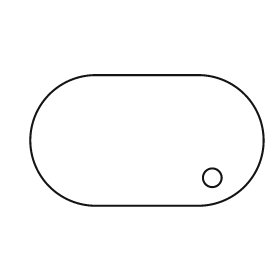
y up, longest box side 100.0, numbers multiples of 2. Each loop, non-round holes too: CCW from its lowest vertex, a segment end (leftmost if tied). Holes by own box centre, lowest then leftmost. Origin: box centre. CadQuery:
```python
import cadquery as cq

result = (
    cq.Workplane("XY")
    .moveTo(-22.0, -28.0)
    .lineTo(22.0, -28.0)
    .threePointArc((50.0, 0.0), (22.0, 28.0))
    .lineTo(-22.0, 28.0)
    .threePointArc((-50.0, 0.0), (-22.0, -28.0))
    .close()
    .moveTo(28.0, -16.0)
    .circle(4.0)
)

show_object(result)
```